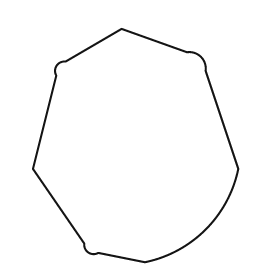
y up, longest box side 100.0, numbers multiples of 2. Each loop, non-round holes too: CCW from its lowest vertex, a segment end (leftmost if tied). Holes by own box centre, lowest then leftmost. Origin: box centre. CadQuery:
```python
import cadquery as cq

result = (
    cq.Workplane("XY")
    .moveTo(4.0, -50.0)
    .threePointArc((30.0, -36.0), (44.0, -10.0))
    .lineTo(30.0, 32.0)
    .threePointArc((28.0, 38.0), (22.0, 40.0))
    .lineTo(-6.0, 50.0)
    .lineTo(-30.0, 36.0)
    .threePointArc((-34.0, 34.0), (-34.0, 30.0))
    .lineTo(-44.0, -10.0)
    .lineTo(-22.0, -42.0)
    .threePointArc((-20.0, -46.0), (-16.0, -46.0))
    .close()
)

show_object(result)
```